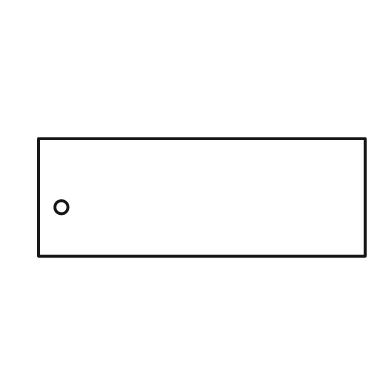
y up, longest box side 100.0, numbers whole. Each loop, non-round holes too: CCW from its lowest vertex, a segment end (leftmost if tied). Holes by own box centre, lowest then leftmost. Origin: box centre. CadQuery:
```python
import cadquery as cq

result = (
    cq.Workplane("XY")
    .moveTo(-50.0, -18.0)
    .lineTo(50.0, -18.0)
    .lineTo(50.0, 18.0)
    .lineTo(-50.0, 18.0)
    .close()
    .moveTo(-43.0, -3.0)
    .circle(2.0)
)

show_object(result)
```